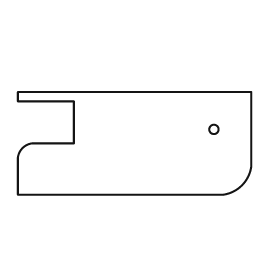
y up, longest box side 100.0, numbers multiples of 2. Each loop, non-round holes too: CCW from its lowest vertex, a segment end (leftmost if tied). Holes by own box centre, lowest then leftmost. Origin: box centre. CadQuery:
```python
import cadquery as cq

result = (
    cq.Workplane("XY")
    .moveTo(-50.0, -22.0)
    .lineTo(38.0, -22.0)
    .threePointArc((46.0, -18.0), (50.0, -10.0))
    .lineTo(50.0, 22.0)
    .lineTo(-50.0, 22.0)
    .lineTo(-50.0, 18.0)
    .lineTo(-26.0, 18.0)
    .lineTo(-26.0, 0.0)
    .lineTo(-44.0, 0.0)
    .threePointArc((-48.0, -2.0), (-50.0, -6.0))
    .close()
    .moveTo(34.0, 6.0)
    .circle(2.0)
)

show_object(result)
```